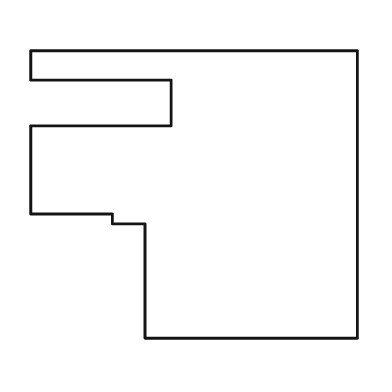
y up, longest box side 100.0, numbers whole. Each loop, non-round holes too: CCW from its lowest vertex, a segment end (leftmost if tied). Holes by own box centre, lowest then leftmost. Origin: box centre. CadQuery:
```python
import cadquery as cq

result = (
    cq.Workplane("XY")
    .moveTo(-15.0, -44.0)
    .lineTo(50.0, -44.0)
    .lineTo(50.0, 44.0)
    .lineTo(-50.0, 44.0)
    .lineTo(-50.0, 35.0)
    .lineTo(-7.0, 35.0)
    .lineTo(-7.0, 21.0)
    .lineTo(-50.0, 21.0)
    .lineTo(-50.0, -6.0)
    .lineTo(-25.0, -6.0)
    .lineTo(-25.0, -9.0)
    .lineTo(-15.0, -9.0)
    .close()
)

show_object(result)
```